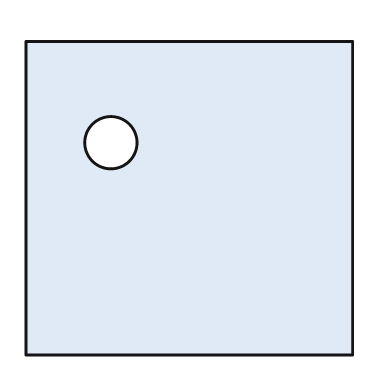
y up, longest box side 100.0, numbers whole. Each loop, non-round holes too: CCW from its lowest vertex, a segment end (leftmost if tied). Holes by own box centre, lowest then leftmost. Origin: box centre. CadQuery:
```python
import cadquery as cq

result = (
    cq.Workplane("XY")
    .moveTo(-50.0, -48.0)
    .lineTo(50.0, -48.0)
    .lineTo(50.0, 48.0)
    .lineTo(-50.0, 48.0)
    .close()
    .moveTo(-24.0, 17.0)
    .circle(8.0)
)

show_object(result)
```